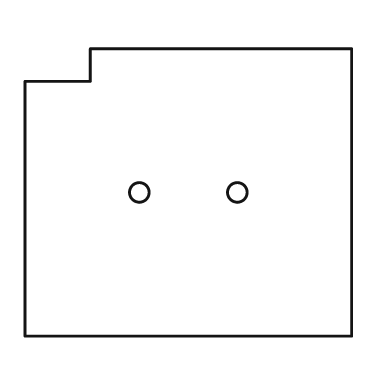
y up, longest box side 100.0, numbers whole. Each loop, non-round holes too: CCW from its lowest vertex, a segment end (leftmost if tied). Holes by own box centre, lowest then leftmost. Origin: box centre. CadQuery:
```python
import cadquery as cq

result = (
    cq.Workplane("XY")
    .moveTo(-50.0, -44.0)
    .lineTo(50.0, -44.0)
    .lineTo(50.0, 44.0)
    .lineTo(-30.0, 44.0)
    .lineTo(-30.0, 34.0)
    .lineTo(-50.0, 34.0)
    .close()
    .moveTo(-15.0, 0.0)
    .circle(3.0)
    .moveTo(15.0, 0.0)
    .circle(3.0)
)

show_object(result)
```